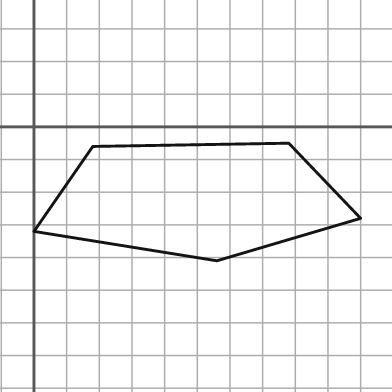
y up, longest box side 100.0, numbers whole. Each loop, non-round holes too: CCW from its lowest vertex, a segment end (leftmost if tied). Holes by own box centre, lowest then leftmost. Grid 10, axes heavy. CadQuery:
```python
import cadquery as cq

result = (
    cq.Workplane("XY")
    .moveTo(56.0, -41.0)
    .lineTo(100.0, -28.0)
    .lineTo(78.0, -5.0)
    .lineTo(18.0, -6.0)
    .lineTo(0.0, -32.0)
    .close()
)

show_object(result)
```